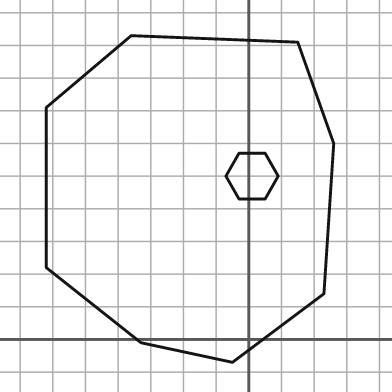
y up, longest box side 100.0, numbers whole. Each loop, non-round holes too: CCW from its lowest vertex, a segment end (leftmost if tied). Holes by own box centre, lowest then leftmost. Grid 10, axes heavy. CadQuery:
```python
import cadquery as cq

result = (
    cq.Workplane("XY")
    .moveTo(-5.0, -7.0)
    .lineTo(23.0, 14.0)
    .lineTo(26.0, 60.0)
    .lineTo(15.0, 91.0)
    .lineTo(-36.0, 93.0)
    .lineTo(-62.0, 71.0)
    .lineTo(-62.0, 22.0)
    .lineTo(-33.0, -1.0)
    .close()
    .moveTo(-3.0, 43.0)
    .lineTo(5.0, 43.0)
    .lineTo(9.0, 50.0)
    .lineTo(5.0, 57.0)
    .lineTo(-3.0, 57.0)
    .lineTo(-7.0, 50.0)
    .close()
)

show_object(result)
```